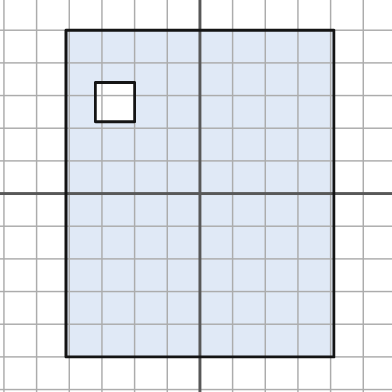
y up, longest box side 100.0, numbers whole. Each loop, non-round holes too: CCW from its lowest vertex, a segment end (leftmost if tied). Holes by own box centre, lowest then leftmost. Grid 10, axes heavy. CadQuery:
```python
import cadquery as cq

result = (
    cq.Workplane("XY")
    .moveTo(-41.0, -50.0)
    .lineTo(41.0, -50.0)
    .lineTo(41.0, 50.0)
    .lineTo(-41.0, 50.0)
    .close()
    .moveTo(-32.0, 22.0)
    .lineTo(-20.0, 22.0)
    .lineTo(-20.0, 34.0)
    .lineTo(-32.0, 34.0)
    .close()
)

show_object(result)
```